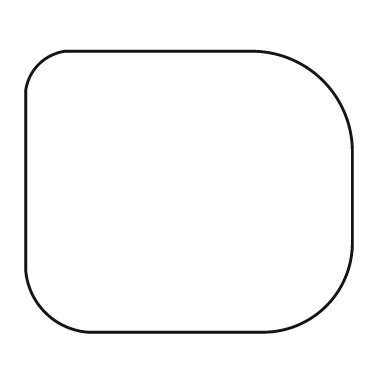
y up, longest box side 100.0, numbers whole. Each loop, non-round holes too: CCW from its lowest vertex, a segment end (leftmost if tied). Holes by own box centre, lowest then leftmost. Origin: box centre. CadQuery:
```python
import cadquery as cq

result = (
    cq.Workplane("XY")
    .moveTo(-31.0, -43.0)
    .lineTo(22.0, -43.0)
    .threePointArc((42.0, -35.0), (50.0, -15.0))
    .lineTo(50.0, 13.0)
    .threePointArc((41.0, 34.0), (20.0, 43.0))
    .lineTo(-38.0, 43.0)
    .threePointArc((-46.0, 39.0), (-50.0, 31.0))
    .lineTo(-50.0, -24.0)
    .threePointArc((-44.0, -37.0), (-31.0, -43.0))
    .close()
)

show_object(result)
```